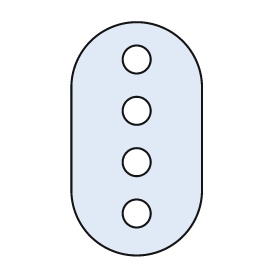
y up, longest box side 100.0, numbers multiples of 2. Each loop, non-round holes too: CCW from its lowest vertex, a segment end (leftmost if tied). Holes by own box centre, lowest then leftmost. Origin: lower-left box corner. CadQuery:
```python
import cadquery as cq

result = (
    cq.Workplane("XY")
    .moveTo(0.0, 28.0)
    .threePointArc((28.0, 0.0), (56.0, 28.0))
    .lineTo(56.0, 72.0)
    .threePointArc((28.0, 100.0), (0.0, 72.0))
    .close()
    .moveTo(28.0, 18.0)
    .circle(6.0)
    .moveTo(28.0, 40.0)
    .circle(6.0)
    .moveTo(28.0, 62.0)
    .circle(6.0)
    .moveTo(28.0, 84.0)
    .circle(6.0)
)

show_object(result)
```